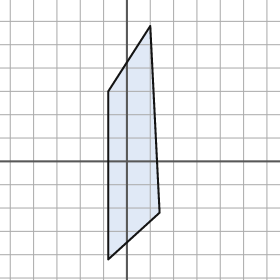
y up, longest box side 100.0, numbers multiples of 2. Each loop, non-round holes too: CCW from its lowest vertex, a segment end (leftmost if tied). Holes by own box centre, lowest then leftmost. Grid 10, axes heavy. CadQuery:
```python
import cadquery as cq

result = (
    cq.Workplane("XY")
    .moveTo(-8.0, -42.0)
    .lineTo(14.0, -22.0)
    .lineTo(10.0, 58.0)
    .lineTo(-8.0, 30.0)
    .close()
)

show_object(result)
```